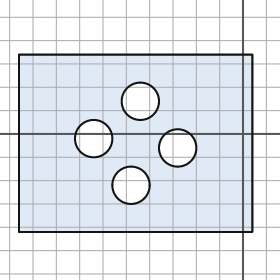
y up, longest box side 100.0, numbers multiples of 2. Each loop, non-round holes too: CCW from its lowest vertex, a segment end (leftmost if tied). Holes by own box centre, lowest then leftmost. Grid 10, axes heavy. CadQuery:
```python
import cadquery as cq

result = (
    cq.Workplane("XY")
    .moveTo(-96.0, -42.0)
    .lineTo(4.0, -42.0)
    .lineTo(4.0, 34.0)
    .lineTo(-96.0, 34.0)
    .close()
    .moveTo(-48.0, -22.0)
    .circle(8.0)
    .moveTo(-28.0, -6.0)
    .circle(8.0)
    .moveTo(-64.0, -2.0)
    .circle(8.0)
    .moveTo(-44.0, 14.0)
    .circle(8.0)
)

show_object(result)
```